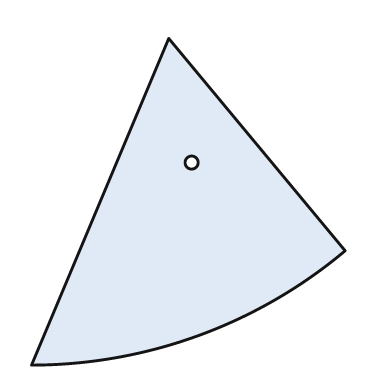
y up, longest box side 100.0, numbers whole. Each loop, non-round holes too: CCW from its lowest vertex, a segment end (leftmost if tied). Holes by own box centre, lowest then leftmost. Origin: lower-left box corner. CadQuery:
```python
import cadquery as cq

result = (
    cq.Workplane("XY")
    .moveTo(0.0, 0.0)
    .threePointArc((51.0, 9.0), (96.0, 35.0))
    .lineTo(42.0, 100.0)
    .close()
    .moveTo(49.0, 62.0)
    .circle(2.0)
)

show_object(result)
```